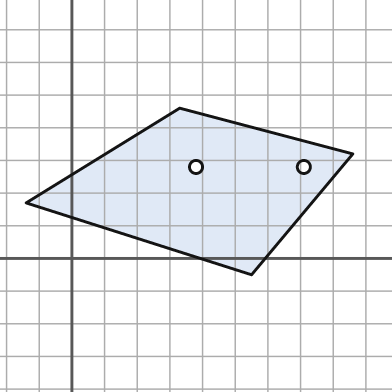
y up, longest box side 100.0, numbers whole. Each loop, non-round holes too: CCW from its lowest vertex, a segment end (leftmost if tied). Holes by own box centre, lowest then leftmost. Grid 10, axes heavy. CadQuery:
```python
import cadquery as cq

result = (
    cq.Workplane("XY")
    .moveTo(55.0, -5.0)
    .lineTo(86.0, 32.0)
    .lineTo(33.0, 46.0)
    .lineTo(-14.0, 17.0)
    .close()
    .moveTo(38.0, 28.0)
    .circle(2.0)
    .moveTo(71.0, 28.0)
    .circle(2.0)
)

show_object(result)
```